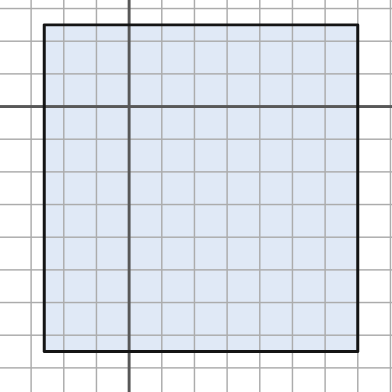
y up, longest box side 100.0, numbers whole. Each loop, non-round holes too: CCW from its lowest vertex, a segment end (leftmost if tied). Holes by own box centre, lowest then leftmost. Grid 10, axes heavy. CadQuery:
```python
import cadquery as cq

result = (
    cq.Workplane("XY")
    .moveTo(-26.0, -75.0)
    .lineTo(70.0, -75.0)
    .lineTo(70.0, 25.0)
    .lineTo(-26.0, 25.0)
    .close()
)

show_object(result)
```